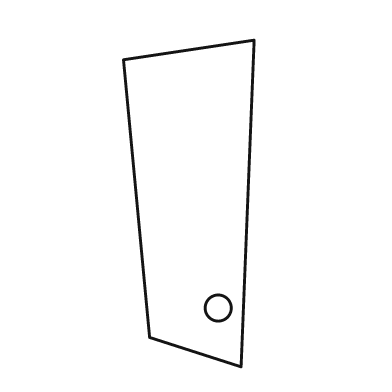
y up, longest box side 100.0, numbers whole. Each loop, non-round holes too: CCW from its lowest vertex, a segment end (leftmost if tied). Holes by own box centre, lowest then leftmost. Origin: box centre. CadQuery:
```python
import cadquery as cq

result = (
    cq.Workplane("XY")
    .moveTo(16.0, -50.0)
    .lineTo(20.0, 50.0)
    .lineTo(-20.0, 44.0)
    .lineTo(-12.0, -41.0)
    .close()
    .moveTo(9.0, -32.0)
    .circle(4.0)
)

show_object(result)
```